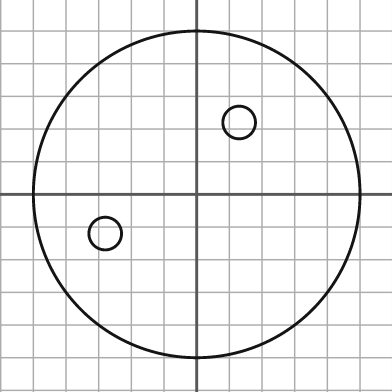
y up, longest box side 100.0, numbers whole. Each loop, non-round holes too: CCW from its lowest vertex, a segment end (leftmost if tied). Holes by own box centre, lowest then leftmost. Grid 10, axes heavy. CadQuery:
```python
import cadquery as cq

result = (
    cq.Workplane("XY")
    .moveTo(0.0, 0.0)
    .circle(50.0)
    .moveTo(-28.0, -12.0)
    .circle(5.0)
    .moveTo(13.0, 22.0)
    .circle(5.0)
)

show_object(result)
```